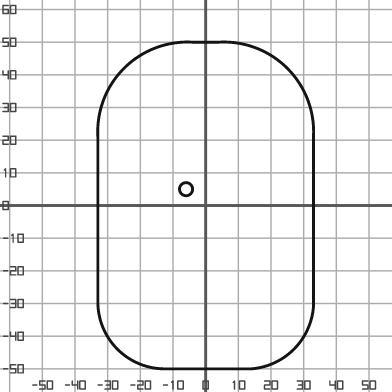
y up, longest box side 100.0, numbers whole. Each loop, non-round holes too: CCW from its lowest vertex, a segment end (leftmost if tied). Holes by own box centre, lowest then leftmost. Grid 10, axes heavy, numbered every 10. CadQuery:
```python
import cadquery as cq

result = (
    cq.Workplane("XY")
    .moveTo(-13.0, -50.0)
    .lineTo(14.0, -50.0)
    .threePointArc((27.0, -44.0), (33.0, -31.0))
    .lineTo(33.0, 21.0)
    .threePointArc((25.0, 42.0), (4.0, 50.0))
    .lineTo(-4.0, 50.0)
    .threePointArc((-25.0, 42.0), (-33.0, 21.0))
    .lineTo(-33.0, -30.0)
    .threePointArc((-27.0, -44.0), (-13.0, -50.0))
    .close()
    .moveTo(-6.0, 5.0)
    .circle(2.0)
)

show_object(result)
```